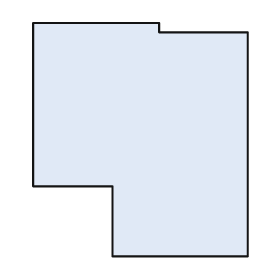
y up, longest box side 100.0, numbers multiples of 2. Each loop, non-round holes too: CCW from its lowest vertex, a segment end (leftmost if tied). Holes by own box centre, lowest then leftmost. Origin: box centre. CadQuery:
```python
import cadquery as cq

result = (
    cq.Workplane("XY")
    .moveTo(-12.0, -50.0)
    .lineTo(46.0, -50.0)
    .lineTo(46.0, 46.0)
    .lineTo(8.0, 46.0)
    .lineTo(8.0, 50.0)
    .lineTo(-46.0, 50.0)
    .lineTo(-46.0, -20.0)
    .lineTo(-12.0, -20.0)
    .close()
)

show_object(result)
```